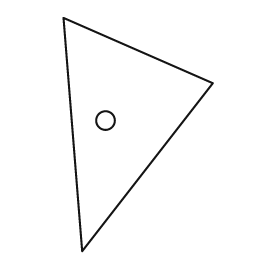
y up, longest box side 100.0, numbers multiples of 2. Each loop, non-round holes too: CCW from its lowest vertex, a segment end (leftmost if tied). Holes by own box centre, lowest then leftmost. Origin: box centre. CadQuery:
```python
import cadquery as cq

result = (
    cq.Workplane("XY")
    .moveTo(-24.0, -50.0)
    .lineTo(32.0, 22.0)
    .lineTo(-32.0, 50.0)
    .close()
    .moveTo(-14.0, 6.0)
    .circle(4.0)
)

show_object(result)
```